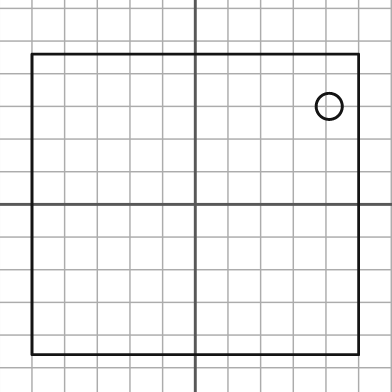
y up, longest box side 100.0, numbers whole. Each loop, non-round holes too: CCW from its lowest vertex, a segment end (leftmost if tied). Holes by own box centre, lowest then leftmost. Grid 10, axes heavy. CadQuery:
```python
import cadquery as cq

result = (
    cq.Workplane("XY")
    .moveTo(-50.0, -46.0)
    .lineTo(50.0, -46.0)
    .lineTo(50.0, 46.0)
    .lineTo(-50.0, 46.0)
    .close()
    .moveTo(41.0, 30.0)
    .circle(4.0)
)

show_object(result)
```